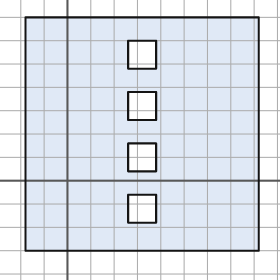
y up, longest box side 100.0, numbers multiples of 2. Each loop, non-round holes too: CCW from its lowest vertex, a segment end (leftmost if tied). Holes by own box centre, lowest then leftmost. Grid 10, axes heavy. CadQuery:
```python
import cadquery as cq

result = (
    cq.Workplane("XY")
    .moveTo(-18.0, -30.0)
    .lineTo(82.0, -30.0)
    .lineTo(82.0, 70.0)
    .lineTo(-18.0, 70.0)
    .close()
    .moveTo(26.0, -18.0)
    .lineTo(38.0, -18.0)
    .lineTo(38.0, -6.0)
    .lineTo(26.0, -6.0)
    .close()
    .moveTo(26.0, 4.0)
    .lineTo(38.0, 4.0)
    .lineTo(38.0, 16.0)
    .lineTo(26.0, 16.0)
    .close()
    .moveTo(26.0, 26.0)
    .lineTo(38.0, 26.0)
    .lineTo(38.0, 38.0)
    .lineTo(26.0, 38.0)
    .close()
    .moveTo(26.0, 48.0)
    .lineTo(38.0, 48.0)
    .lineTo(38.0, 60.0)
    .lineTo(26.0, 60.0)
    .close()
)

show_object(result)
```